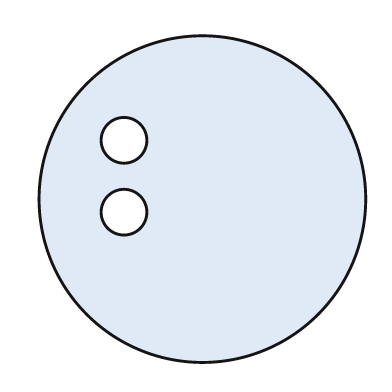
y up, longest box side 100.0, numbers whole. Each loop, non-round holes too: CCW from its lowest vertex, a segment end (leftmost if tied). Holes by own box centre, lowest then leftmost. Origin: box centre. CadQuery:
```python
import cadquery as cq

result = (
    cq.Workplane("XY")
    .moveTo(0.0, 0.0)
    .circle(50.0)
    .moveTo(-24.0, -4.0)
    .circle(7.0)
    .moveTo(-24.0, 18.0)
    .circle(7.0)
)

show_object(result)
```